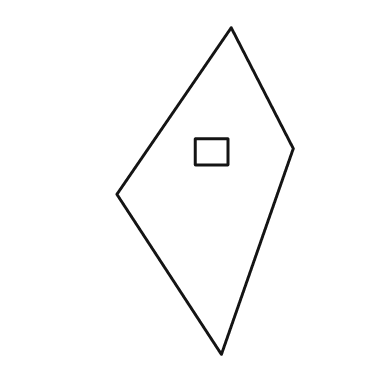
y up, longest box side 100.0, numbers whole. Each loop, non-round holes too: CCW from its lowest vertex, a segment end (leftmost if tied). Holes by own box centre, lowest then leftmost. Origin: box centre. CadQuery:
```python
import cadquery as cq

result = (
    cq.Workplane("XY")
    .moveTo(5.0, -50.0)
    .lineTo(27.0, 13.0)
    .lineTo(8.0, 50.0)
    .lineTo(-27.0, -1.0)
    .close()
    .moveTo(-3.0, 8.0)
    .lineTo(7.0, 8.0)
    .lineTo(7.0, 16.0)
    .lineTo(-3.0, 16.0)
    .close()
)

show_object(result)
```